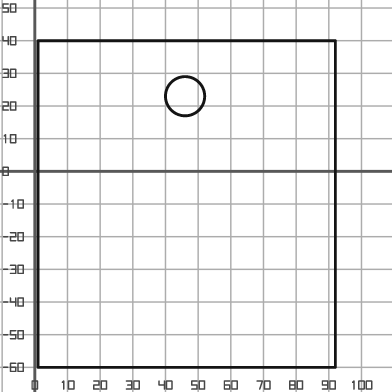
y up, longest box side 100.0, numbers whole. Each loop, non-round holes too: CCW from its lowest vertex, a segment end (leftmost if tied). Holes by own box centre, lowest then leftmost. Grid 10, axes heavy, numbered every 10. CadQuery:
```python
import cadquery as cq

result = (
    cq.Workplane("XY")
    .moveTo(1.0, -60.0)
    .lineTo(92.0, -60.0)
    .lineTo(92.0, 40.0)
    .lineTo(1.0, 40.0)
    .close()
    .moveTo(46.0, 23.0)
    .circle(6.0)
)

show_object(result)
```